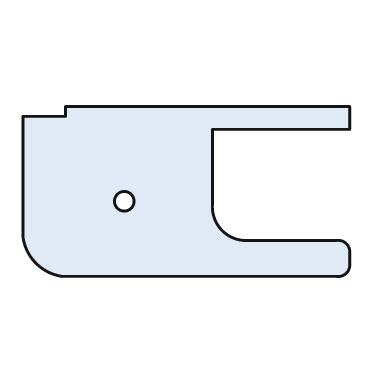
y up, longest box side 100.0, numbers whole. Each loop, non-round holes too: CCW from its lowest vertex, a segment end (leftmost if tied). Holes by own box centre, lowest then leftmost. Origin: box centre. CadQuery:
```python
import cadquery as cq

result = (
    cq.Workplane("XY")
    .moveTo(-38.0, -26.0)
    .lineTo(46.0, -26.0)
    .threePointArc((49.0, -25.0), (50.0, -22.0))
    .lineTo(50.0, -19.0)
    .threePointArc((49.0, -16.0), (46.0, -15.0))
    .lineTo(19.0, -15.0)
    .threePointArc((11.0, -12.0), (8.0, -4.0))
    .lineTo(8.0, 19.0)
    .lineTo(50.0, 19.0)
    .lineTo(50.0, 26.0)
    .lineTo(-37.0, 26.0)
    .lineTo(-37.0, 23.0)
    .lineTo(-50.0, 23.0)
    .lineTo(-50.0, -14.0)
    .threePointArc((-46.0, -22.0), (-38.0, -26.0))
    .close()
    .moveTo(-19.0, -3.0)
    .circle(3.0)
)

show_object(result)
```